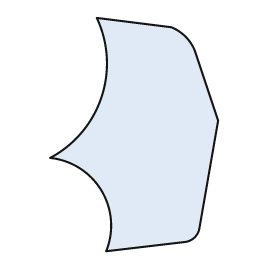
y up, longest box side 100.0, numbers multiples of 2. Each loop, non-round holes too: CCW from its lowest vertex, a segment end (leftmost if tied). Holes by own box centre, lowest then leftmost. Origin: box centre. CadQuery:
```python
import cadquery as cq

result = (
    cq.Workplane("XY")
    .moveTo(-12.0, -50.0)
    .lineTo(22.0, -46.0)
    .threePointArc((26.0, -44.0), (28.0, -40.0))
    .lineTo(36.0, 6.0)
    .lineTo(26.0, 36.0)
    .threePointArc((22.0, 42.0), (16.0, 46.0))
    .lineTo(-16.0, 50.0)
    .threePointArc((-14.0, 16.0), (-36.0, -10.0))
    .threePointArc((-14.0, -24.0), (-12.0, -50.0))
    .close()
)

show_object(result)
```